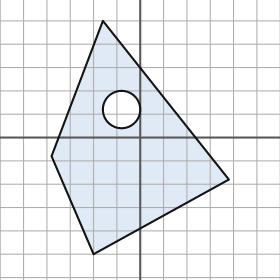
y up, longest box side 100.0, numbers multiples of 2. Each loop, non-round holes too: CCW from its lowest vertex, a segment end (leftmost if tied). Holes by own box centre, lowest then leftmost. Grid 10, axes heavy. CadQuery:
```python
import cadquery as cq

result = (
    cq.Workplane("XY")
    .moveTo(-20.0, -50.0)
    .lineTo(38.0, -18.0)
    .lineTo(-16.0, 50.0)
    .lineTo(-38.0, -8.0)
    .close()
    .moveTo(-8.0, 12.0)
    .circle(8.0)
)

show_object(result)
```